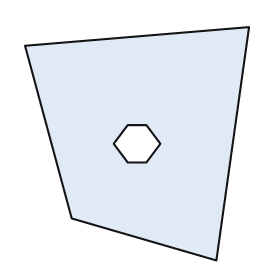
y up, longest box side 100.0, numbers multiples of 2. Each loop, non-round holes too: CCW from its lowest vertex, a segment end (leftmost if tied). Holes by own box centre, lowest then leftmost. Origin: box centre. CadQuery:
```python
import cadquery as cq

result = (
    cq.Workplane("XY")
    .moveTo(34.0, -50.0)
    .lineTo(48.0, 50.0)
    .lineTo(-48.0, 42.0)
    .lineTo(-28.0, -32.0)
    .close()
    .moveTo(-4.0, -8.0)
    .lineTo(4.0, -8.0)
    .lineTo(10.0, 0.0)
    .lineTo(4.0, 8.0)
    .lineTo(-4.0, 8.0)
    .lineTo(-10.0, 0.0)
    .close()
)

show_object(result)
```